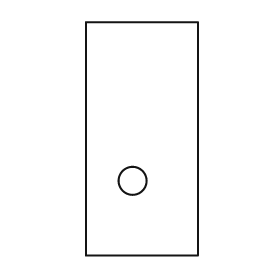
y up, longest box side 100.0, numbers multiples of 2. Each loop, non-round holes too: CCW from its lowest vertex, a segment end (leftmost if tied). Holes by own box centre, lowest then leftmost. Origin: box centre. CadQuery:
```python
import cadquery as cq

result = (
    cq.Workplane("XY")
    .moveTo(-24.0, -50.0)
    .lineTo(24.0, -50.0)
    .lineTo(24.0, 50.0)
    .lineTo(-24.0, 50.0)
    .close()
    .moveTo(-4.0, -18.0)
    .circle(6.0)
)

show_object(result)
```